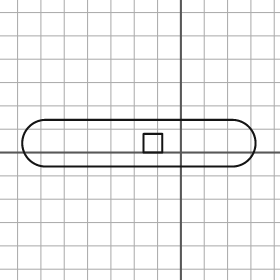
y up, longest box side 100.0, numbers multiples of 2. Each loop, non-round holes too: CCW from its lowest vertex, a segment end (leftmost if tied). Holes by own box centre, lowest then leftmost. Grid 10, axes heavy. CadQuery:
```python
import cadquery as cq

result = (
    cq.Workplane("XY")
    .moveTo(-58.0, -6.0)
    .lineTo(22.0, -6.0)
    .threePointArc((32.0, 4.0), (22.0, 14.0))
    .lineTo(-58.0, 14.0)
    .threePointArc((-68.0, 4.0), (-58.0, -6.0))
    .close()
    .moveTo(-16.0, 0.0)
    .lineTo(-8.0, 0.0)
    .lineTo(-8.0, 8.0)
    .lineTo(-16.0, 8.0)
    .close()
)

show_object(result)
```